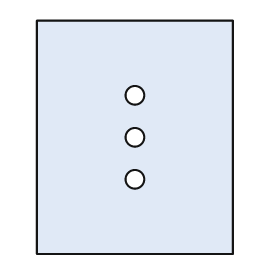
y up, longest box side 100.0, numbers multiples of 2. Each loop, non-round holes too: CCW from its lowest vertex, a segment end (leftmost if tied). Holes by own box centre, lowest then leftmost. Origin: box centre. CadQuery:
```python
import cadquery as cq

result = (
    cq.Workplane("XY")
    .moveTo(-42.0, -50.0)
    .lineTo(42.0, -50.0)
    .lineTo(42.0, 50.0)
    .lineTo(-42.0, 50.0)
    .close()
    .moveTo(0.0, -18.0)
    .circle(4.0)
    .moveTo(0.0, 0.0)
    .circle(4.0)
    .moveTo(0.0, 18.0)
    .circle(4.0)
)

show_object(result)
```